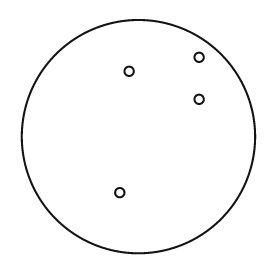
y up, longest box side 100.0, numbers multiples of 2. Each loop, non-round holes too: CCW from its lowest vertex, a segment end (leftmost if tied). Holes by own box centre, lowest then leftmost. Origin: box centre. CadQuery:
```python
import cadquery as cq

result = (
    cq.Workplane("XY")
    .moveTo(0.0, 0.0)
    .circle(50.0)
    .moveTo(-8.0, -24.0)
    .circle(2.0)
    .moveTo(26.0, 16.0)
    .circle(2.0)
    .moveTo(-4.0, 28.0)
    .circle(2.0)
    .moveTo(26.0, 34.0)
    .circle(2.0)
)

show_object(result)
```